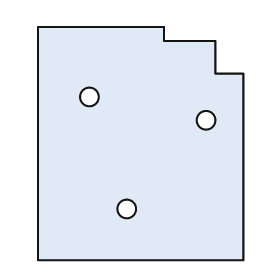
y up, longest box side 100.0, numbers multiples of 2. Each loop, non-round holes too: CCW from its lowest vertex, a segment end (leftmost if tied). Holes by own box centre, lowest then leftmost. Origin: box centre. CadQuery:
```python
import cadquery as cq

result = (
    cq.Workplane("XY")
    .moveTo(-44.0, -50.0)
    .lineTo(44.0, -50.0)
    .lineTo(44.0, 30.0)
    .lineTo(32.0, 30.0)
    .lineTo(32.0, 44.0)
    .lineTo(10.0, 44.0)
    .lineTo(10.0, 50.0)
    .lineTo(-44.0, 50.0)
    .close()
    .moveTo(-6.0, -28.0)
    .circle(4.0)
    .moveTo(28.0, 10.0)
    .circle(4.0)
    .moveTo(-22.0, 20.0)
    .circle(4.0)
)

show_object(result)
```